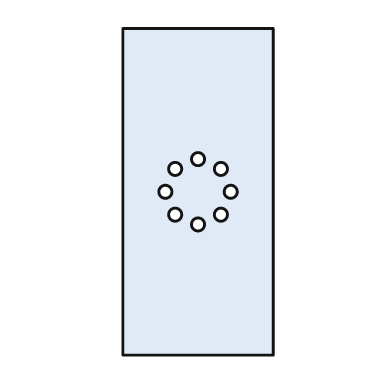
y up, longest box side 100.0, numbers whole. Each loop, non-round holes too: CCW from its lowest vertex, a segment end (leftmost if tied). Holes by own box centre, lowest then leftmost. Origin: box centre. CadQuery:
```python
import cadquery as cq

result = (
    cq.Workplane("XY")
    .moveTo(-23.0, -50.0)
    .lineTo(23.0, -50.0)
    .lineTo(23.0, 50.0)
    .lineTo(-23.0, 50.0)
    .close()
    .moveTo(0.0, -10.0)
    .circle(2.0)
    .moveTo(-7.0, -7.0)
    .circle(2.0)
    .moveTo(7.0, -7.0)
    .circle(2.0)
    .moveTo(-10.0, 0.0)
    .circle(2.0)
    .moveTo(10.0, 0.0)
    .circle(2.0)
    .moveTo(-7.0, 7.0)
    .circle(2.0)
    .moveTo(7.0, 7.0)
    .circle(2.0)
    .moveTo(0.0, 10.0)
    .circle(2.0)
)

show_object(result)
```